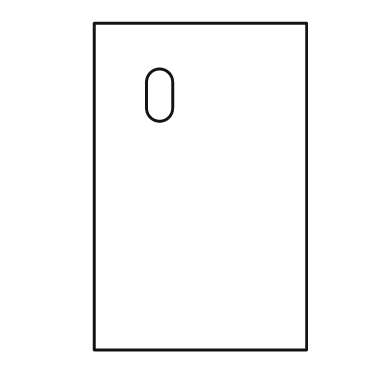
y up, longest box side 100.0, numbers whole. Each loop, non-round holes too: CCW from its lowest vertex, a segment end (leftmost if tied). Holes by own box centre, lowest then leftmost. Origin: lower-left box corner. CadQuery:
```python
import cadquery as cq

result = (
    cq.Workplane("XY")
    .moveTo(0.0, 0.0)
    .lineTo(65.0, 0.0)
    .lineTo(65.0, 100.0)
    .lineTo(0.0, 100.0)
    .close()
    .moveTo(16.0, 74.0)
    .threePointArc((20.0, 70.0), (24.0, 74.0))
    .lineTo(24.0, 82.0)
    .threePointArc((20.0, 86.0), (16.0, 82.0))
    .close()
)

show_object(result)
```